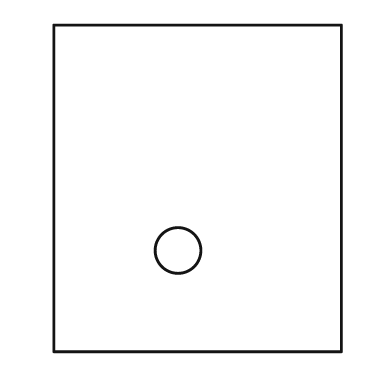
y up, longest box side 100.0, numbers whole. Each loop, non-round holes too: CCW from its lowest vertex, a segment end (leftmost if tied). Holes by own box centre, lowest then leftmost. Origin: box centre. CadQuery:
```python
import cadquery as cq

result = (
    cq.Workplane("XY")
    .moveTo(-44.0, -50.0)
    .lineTo(44.0, -50.0)
    .lineTo(44.0, 50.0)
    .lineTo(-44.0, 50.0)
    .close()
    .moveTo(-6.0, -19.0)
    .circle(7.0)
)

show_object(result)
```